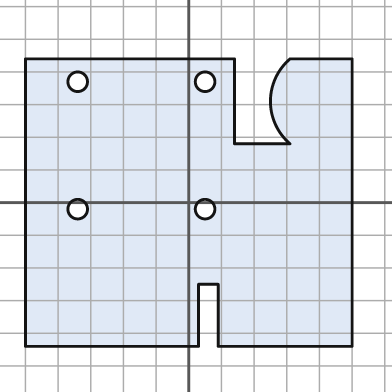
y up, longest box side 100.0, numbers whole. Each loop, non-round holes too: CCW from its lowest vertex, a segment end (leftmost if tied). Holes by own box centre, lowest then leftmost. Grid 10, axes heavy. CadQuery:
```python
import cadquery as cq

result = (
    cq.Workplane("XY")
    .moveTo(-50.0, -44.0)
    .lineTo(3.0, -44.0)
    .lineTo(3.0, -25.0)
    .lineTo(9.0, -25.0)
    .lineTo(9.0, -44.0)
    .lineTo(50.0, -44.0)
    .lineTo(50.0, 44.0)
    .lineTo(31.0, 44.0)
    .threePointArc((25.0, 31.0), (31.0, 18.0))
    .lineTo(14.0, 18.0)
    .lineTo(14.0, 44.0)
    .lineTo(-50.0, 44.0)
    .close()
    .moveTo(-34.0, -2.0)
    .circle(3.0)
    .moveTo(5.0, -2.0)
    .circle(3.0)
    .moveTo(-34.0, 37.0)
    .circle(3.0)
    .moveTo(5.0, 37.0)
    .circle(3.0)
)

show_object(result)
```